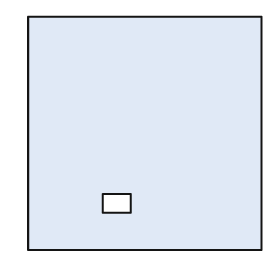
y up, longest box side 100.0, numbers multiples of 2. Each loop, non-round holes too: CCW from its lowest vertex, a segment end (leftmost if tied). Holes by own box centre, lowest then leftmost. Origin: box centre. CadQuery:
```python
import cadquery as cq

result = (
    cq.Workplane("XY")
    .moveTo(-50.0, -50.0)
    .lineTo(50.0, -50.0)
    .lineTo(50.0, 50.0)
    .lineTo(-50.0, 50.0)
    .close()
    .moveTo(-18.0, -34.0)
    .lineTo(-6.0, -34.0)
    .lineTo(-6.0, -26.0)
    .lineTo(-18.0, -26.0)
    .close()
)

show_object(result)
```